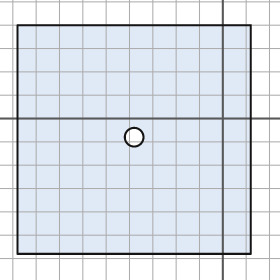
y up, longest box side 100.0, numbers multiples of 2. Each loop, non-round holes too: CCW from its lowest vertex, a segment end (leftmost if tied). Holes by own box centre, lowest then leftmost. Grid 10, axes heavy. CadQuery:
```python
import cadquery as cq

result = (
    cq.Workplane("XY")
    .moveTo(-88.0, -58.0)
    .lineTo(12.0, -58.0)
    .lineTo(12.0, 40.0)
    .lineTo(-88.0, 40.0)
    .close()
    .moveTo(-38.0, -8.0)
    .circle(4.0)
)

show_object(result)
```